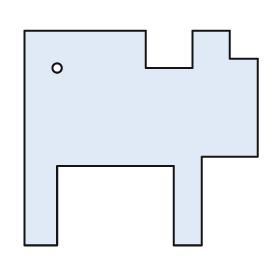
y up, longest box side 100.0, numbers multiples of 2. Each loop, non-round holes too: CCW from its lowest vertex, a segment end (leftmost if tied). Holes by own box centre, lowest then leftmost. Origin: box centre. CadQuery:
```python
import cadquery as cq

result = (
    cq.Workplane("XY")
    .moveTo(-50.0, -46.0)
    .lineTo(-36.0, -46.0)
    .lineTo(-36.0, -12.0)
    .lineTo(14.0, -12.0)
    .lineTo(14.0, -46.0)
    .lineTo(26.0, -46.0)
    .lineTo(26.0, -8.0)
    .lineTo(50.0, -8.0)
    .lineTo(50.0, 34.0)
    .lineTo(38.0, 34.0)
    .lineTo(38.0, 46.0)
    .lineTo(22.0, 46.0)
    .lineTo(22.0, 30.0)
    .lineTo(2.0, 30.0)
    .lineTo(2.0, 46.0)
    .lineTo(-50.0, 46.0)
    .close()
    .moveTo(-36.0, 30.0)
    .circle(2.0)
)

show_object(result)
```